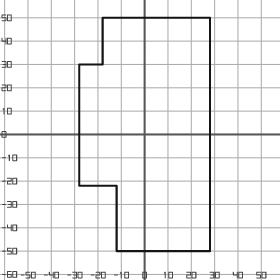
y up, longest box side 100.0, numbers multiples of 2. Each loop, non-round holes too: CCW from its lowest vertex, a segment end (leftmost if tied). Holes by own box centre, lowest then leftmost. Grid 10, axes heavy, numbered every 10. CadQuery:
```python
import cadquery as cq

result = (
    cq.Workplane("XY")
    .moveTo(-12.0, -50.0)
    .lineTo(28.0, -50.0)
    .lineTo(28.0, 50.0)
    .lineTo(-18.0, 50.0)
    .lineTo(-18.0, 30.0)
    .lineTo(-28.0, 30.0)
    .lineTo(-28.0, -22.0)
    .lineTo(-12.0, -22.0)
    .close()
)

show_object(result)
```